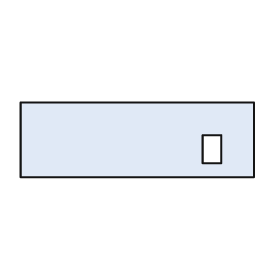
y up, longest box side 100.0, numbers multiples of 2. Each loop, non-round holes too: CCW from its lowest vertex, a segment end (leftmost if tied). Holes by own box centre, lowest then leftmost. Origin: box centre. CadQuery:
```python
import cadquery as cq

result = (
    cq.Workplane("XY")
    .moveTo(-50.0, -16.0)
    .lineTo(50.0, -16.0)
    .lineTo(50.0, 16.0)
    .lineTo(-50.0, 16.0)
    .close()
    .moveTo(28.0, -10.0)
    .lineTo(36.0, -10.0)
    .lineTo(36.0, 2.0)
    .lineTo(28.0, 2.0)
    .close()
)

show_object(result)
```